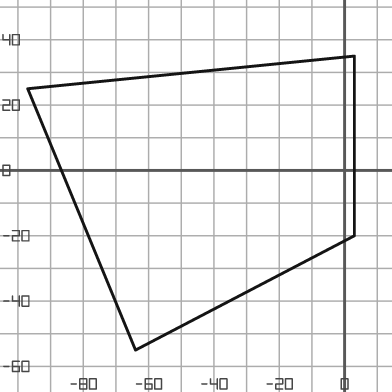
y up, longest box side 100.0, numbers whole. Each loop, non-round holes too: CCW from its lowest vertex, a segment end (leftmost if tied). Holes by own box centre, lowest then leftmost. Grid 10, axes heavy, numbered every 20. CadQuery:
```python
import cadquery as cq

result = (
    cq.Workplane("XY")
    .moveTo(-64.0, -55.0)
    .lineTo(3.0, -20.0)
    .lineTo(3.0, 35.0)
    .lineTo(-97.0, 25.0)
    .close()
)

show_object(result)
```